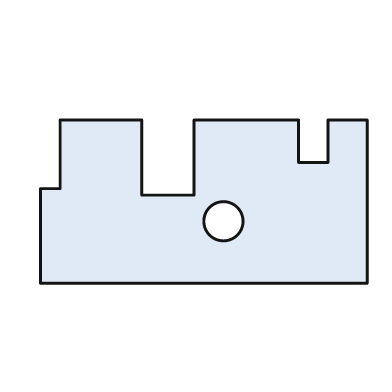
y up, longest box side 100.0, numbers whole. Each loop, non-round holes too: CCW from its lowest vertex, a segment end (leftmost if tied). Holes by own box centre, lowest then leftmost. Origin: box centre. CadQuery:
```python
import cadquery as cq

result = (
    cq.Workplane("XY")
    .moveTo(-50.0, -25.0)
    .lineTo(50.0, -25.0)
    .lineTo(50.0, 25.0)
    .lineTo(38.0, 25.0)
    .lineTo(38.0, 12.0)
    .lineTo(29.0, 12.0)
    .lineTo(29.0, 25.0)
    .lineTo(-3.0, 25.0)
    .lineTo(-3.0, 2.0)
    .lineTo(-19.0, 2.0)
    .lineTo(-19.0, 25.0)
    .lineTo(-44.0, 25.0)
    .lineTo(-44.0, 4.0)
    .lineTo(-50.0, 4.0)
    .close()
    .moveTo(6.0, -6.0)
    .circle(6.0)
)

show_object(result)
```